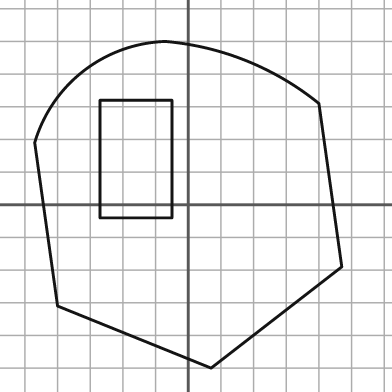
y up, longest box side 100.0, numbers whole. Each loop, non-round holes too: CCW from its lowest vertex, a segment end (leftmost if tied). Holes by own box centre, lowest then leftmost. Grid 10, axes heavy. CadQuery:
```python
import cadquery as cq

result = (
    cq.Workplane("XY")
    .moveTo(7.0, -50.0)
    .lineTo(47.0, -19.0)
    .lineTo(40.0, 31.0)
    .threePointArc((18.0, 44.0), (-7.0, 50.0))
    .threePointArc((-32.0, 41.0), (-47.0, 19.0))
    .lineTo(-40.0, -31.0)
    .close()
    .moveTo(-27.0, -4.0)
    .lineTo(-5.0, -4.0)
    .lineTo(-5.0, 32.0)
    .lineTo(-27.0, 32.0)
    .close()
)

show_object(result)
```